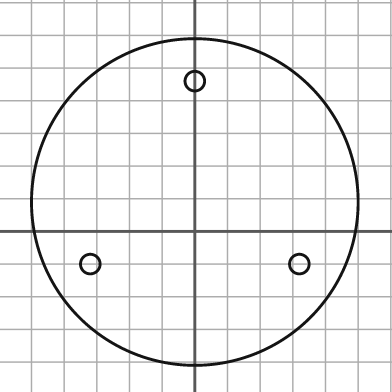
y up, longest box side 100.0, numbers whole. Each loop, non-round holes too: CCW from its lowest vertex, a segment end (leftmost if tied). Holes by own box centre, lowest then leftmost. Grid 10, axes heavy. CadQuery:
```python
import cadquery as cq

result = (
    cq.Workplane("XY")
    .moveTo(0.0, 9.0)
    .circle(50.0)
    .moveTo(-32.0, -10.0)
    .circle(3.0)
    .moveTo(32.0, -10.0)
    .circle(3.0)
    .moveTo(0.0, 46.0)
    .circle(3.0)
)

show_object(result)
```